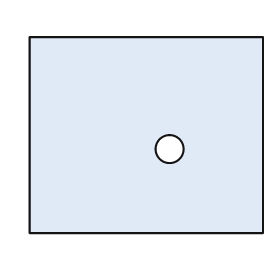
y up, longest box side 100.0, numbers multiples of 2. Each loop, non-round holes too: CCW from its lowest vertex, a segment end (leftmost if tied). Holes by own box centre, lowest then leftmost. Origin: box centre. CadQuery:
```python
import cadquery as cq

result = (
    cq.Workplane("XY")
    .moveTo(-50.0, -42.0)
    .lineTo(50.0, -42.0)
    .lineTo(50.0, 42.0)
    .lineTo(-50.0, 42.0)
    .close()
    .moveTo(10.0, -6.0)
    .circle(6.0)
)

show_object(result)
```